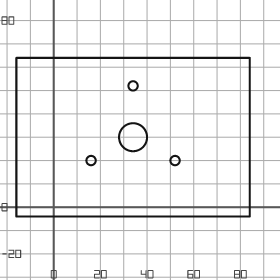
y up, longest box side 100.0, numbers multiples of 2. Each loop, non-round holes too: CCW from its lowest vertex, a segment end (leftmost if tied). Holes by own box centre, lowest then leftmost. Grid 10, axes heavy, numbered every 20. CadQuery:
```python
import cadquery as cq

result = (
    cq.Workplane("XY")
    .moveTo(-16.0, -4.0)
    .lineTo(84.0, -4.0)
    .lineTo(84.0, 64.0)
    .lineTo(-16.0, 64.0)
    .close()
    .moveTo(16.0, 20.0)
    .circle(2.0)
    .moveTo(52.0, 20.0)
    .circle(2.0)
    .moveTo(34.0, 30.0)
    .circle(6.0)
    .moveTo(34.0, 52.0)
    .circle(2.0)
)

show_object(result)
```